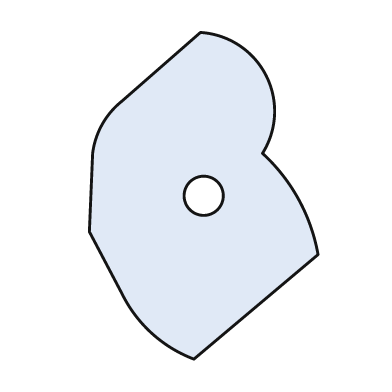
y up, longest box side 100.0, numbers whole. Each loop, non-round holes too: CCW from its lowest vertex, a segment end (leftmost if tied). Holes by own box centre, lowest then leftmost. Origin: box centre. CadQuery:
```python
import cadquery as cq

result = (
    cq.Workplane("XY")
    .moveTo(-3.0, -50.0)
    .lineTo(35.0, -18.0)
    .threePointArc((29.0, -1.0), (18.0, 13.0))
    .threePointArc((19.0, 37.0), (-1.0, 50.0))
    .lineTo(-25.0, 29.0)
    .threePointArc((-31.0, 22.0), (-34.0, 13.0))
    .lineTo(-35.0, -11.0)
    .lineTo(-25.0, -30.0)
    .threePointArc((-16.0, -42.0), (-3.0, -50.0))
    .close()
    .moveTo(0.0, 0.0)
    .circle(6.0)
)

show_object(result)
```